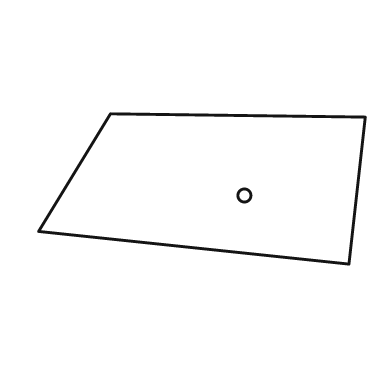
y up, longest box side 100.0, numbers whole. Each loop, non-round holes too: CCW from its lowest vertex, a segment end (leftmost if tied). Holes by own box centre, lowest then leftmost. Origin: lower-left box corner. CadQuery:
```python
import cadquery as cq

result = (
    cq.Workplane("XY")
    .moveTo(95.0, 0.0)
    .lineTo(100.0, 45.0)
    .lineTo(22.0, 46.0)
    .lineTo(0.0, 10.0)
    .close()
    .moveTo(63.0, 21.0)
    .circle(2.0)
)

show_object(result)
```